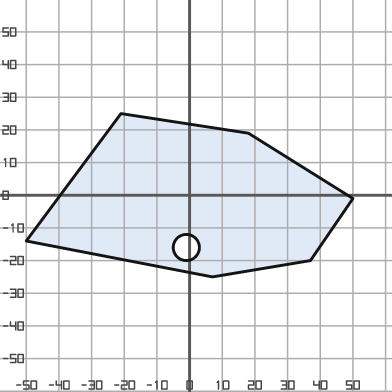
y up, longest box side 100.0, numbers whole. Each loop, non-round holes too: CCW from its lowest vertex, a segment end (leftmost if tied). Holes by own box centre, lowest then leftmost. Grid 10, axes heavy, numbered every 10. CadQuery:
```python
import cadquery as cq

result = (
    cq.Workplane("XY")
    .moveTo(7.0, -25.0)
    .lineTo(37.0, -20.0)
    .lineTo(50.0, -1.0)
    .lineTo(18.0, 19.0)
    .lineTo(-21.0, 25.0)
    .lineTo(-50.0, -14.0)
    .close()
    .moveTo(-1.0, -16.0)
    .circle(4.0)
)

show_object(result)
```